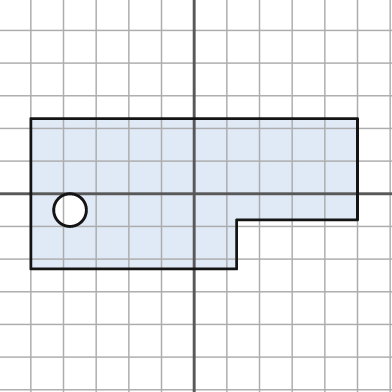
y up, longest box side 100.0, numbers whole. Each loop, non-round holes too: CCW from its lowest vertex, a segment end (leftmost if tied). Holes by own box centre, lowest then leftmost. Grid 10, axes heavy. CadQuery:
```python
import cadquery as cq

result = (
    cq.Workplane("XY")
    .moveTo(-50.0, -23.0)
    .lineTo(13.0, -23.0)
    .lineTo(13.0, -8.0)
    .lineTo(50.0, -8.0)
    .lineTo(50.0, 23.0)
    .lineTo(-50.0, 23.0)
    .close()
    .moveTo(-38.0, -5.0)
    .circle(5.0)
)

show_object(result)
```